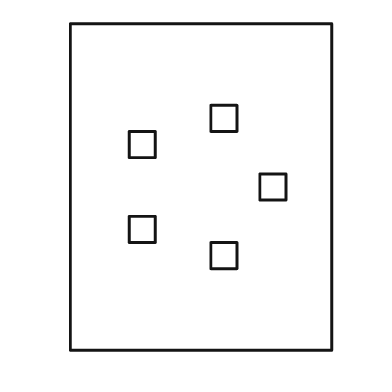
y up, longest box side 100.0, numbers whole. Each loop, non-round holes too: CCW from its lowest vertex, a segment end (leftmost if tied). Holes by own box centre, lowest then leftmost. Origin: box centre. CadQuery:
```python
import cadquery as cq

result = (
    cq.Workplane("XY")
    .moveTo(-40.0, -50.0)
    .lineTo(40.0, -50.0)
    .lineTo(40.0, 50.0)
    .lineTo(-40.0, 50.0)
    .close()
    .moveTo(3.0, -25.0)
    .lineTo(11.0, -25.0)
    .lineTo(11.0, -17.0)
    .lineTo(3.0, -17.0)
    .close()
    .moveTo(-22.0, -17.0)
    .lineTo(-14.0, -17.0)
    .lineTo(-14.0, -9.0)
    .lineTo(-22.0, -9.0)
    .close()
    .moveTo(18.0, -4.0)
    .lineTo(26.0, -4.0)
    .lineTo(26.0, 4.0)
    .lineTo(18.0, 4.0)
    .close()
    .moveTo(-22.0, 9.0)
    .lineTo(-14.0, 9.0)
    .lineTo(-14.0, 17.0)
    .lineTo(-22.0, 17.0)
    .close()
    .moveTo(3.0, 17.0)
    .lineTo(11.0, 17.0)
    .lineTo(11.0, 25.0)
    .lineTo(3.0, 25.0)
    .close()
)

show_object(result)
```